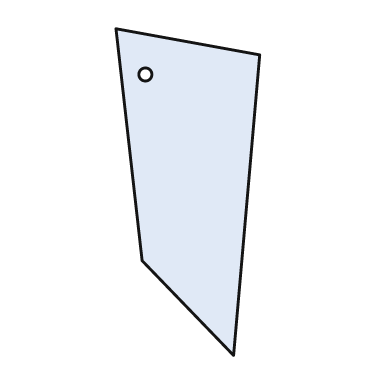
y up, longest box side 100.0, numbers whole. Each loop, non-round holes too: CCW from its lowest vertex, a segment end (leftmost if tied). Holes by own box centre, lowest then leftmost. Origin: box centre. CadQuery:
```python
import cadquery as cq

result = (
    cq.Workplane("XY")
    .moveTo(14.0, -50.0)
    .lineTo(22.0, 42.0)
    .lineTo(-22.0, 50.0)
    .lineTo(-14.0, -21.0)
    .close()
    .moveTo(-13.0, 36.0)
    .circle(2.0)
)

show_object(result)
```